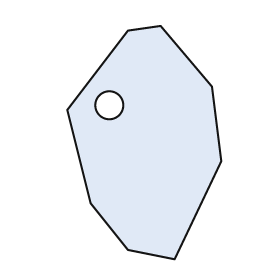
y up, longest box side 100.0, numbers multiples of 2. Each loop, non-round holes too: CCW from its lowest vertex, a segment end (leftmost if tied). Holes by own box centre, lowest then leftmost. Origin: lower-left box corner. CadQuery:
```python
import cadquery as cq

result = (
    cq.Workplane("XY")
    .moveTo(46.0, 0.0)
    .lineTo(66.0, 42.0)
    .lineTo(62.0, 74.0)
    .lineTo(40.0, 100.0)
    .lineTo(26.0, 98.0)
    .lineTo(0.0, 64.0)
    .lineTo(10.0, 24.0)
    .lineTo(26.0, 4.0)
    .close()
    .moveTo(18.0, 66.0)
    .circle(6.0)
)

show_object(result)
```